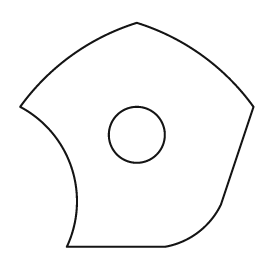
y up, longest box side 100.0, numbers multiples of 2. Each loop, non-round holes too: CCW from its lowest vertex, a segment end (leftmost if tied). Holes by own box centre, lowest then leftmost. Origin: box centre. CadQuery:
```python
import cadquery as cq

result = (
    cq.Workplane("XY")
    .moveTo(-30.0, -48.0)
    .lineTo(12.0, -48.0)
    .threePointArc((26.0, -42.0), (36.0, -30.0))
    .lineTo(50.0, 12.0)
    .threePointArc((28.0, 34.0), (0.0, 48.0))
    .threePointArc((-28.0, 34.0), (-50.0, 12.0))
    .threePointArc((-28.0, -14.0), (-30.0, -48.0))
    .close()
    .moveTo(0.0, 0.0)
    .circle(12.0)
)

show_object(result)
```